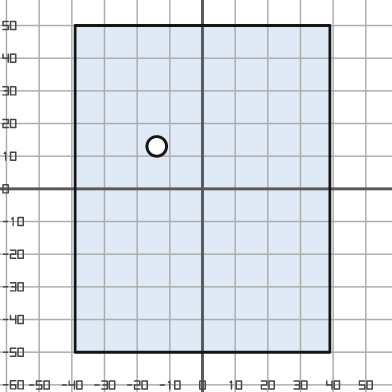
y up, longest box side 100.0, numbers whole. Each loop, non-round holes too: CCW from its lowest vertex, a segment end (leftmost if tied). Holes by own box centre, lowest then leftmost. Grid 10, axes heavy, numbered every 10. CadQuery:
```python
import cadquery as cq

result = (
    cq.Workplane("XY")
    .moveTo(-39.0, -50.0)
    .lineTo(39.0, -50.0)
    .lineTo(39.0, 50.0)
    .lineTo(-39.0, 50.0)
    .close()
    .moveTo(-14.0, 13.0)
    .circle(3.0)
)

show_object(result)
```